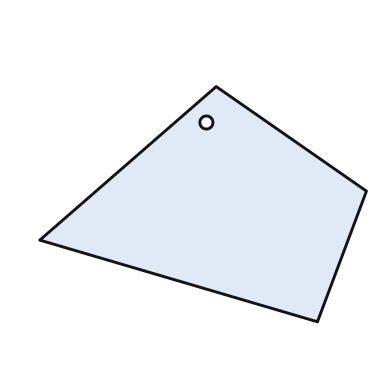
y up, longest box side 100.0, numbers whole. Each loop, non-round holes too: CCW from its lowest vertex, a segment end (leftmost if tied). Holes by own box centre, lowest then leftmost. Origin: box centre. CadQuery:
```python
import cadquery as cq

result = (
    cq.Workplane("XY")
    .moveTo(35.0, -36.0)
    .lineTo(50.0, 4.0)
    .lineTo(4.0, 36.0)
    .lineTo(-50.0, -11.0)
    .close()
    .moveTo(1.0, 25.0)
    .circle(2.0)
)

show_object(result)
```